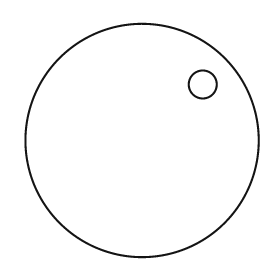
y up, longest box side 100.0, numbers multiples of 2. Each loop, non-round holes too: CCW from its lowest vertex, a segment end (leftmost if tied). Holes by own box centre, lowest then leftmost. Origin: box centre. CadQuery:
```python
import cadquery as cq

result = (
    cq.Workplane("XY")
    .moveTo(0.0, 0.0)
    .circle(50.0)
    .moveTo(26.0, 24.0)
    .circle(6.0)
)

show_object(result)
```